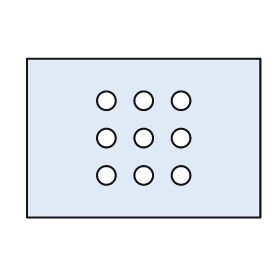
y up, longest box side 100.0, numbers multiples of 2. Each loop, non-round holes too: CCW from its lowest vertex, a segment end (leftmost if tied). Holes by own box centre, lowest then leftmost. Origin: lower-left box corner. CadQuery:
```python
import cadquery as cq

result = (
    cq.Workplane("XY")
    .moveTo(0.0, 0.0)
    .lineTo(100.0, 0.0)
    .lineTo(100.0, 68.0)
    .lineTo(0.0, 68.0)
    .close()
    .moveTo(34.0, 18.0)
    .circle(4.0)
    .moveTo(50.0, 18.0)
    .circle(4.0)
    .moveTo(66.0, 18.0)
    .circle(4.0)
    .moveTo(34.0, 34.0)
    .circle(4.0)
    .moveTo(50.0, 34.0)
    .circle(4.0)
    .moveTo(66.0, 34.0)
    .circle(4.0)
    .moveTo(34.0, 50.0)
    .circle(4.0)
    .moveTo(50.0, 50.0)
    .circle(4.0)
    .moveTo(66.0, 50.0)
    .circle(4.0)
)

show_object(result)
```